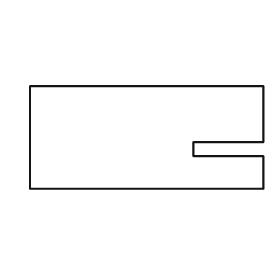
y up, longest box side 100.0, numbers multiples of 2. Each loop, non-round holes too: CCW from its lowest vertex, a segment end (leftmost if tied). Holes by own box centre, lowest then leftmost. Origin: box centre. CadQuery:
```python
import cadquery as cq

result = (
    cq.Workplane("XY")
    .moveTo(-50.0, -22.0)
    .lineTo(50.0, -22.0)
    .lineTo(50.0, -8.0)
    .lineTo(20.0, -8.0)
    .lineTo(20.0, -2.0)
    .lineTo(50.0, -2.0)
    .lineTo(50.0, 22.0)
    .lineTo(-50.0, 22.0)
    .close()
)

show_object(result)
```